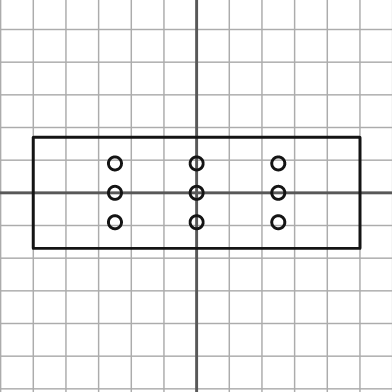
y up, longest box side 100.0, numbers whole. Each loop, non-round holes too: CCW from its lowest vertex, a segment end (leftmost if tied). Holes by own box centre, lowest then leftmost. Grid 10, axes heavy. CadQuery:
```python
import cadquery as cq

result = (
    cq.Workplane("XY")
    .moveTo(-50.0, -17.0)
    .lineTo(50.0, -17.0)
    .lineTo(50.0, 17.0)
    .lineTo(-50.0, 17.0)
    .close()
    .moveTo(-25.0, -9.0)
    .circle(2.0)
    .moveTo(0.0, -9.0)
    .circle(2.0)
    .moveTo(25.0, -9.0)
    .circle(2.0)
    .moveTo(-25.0, 0.0)
    .circle(2.0)
    .moveTo(0.0, 0.0)
    .circle(2.0)
    .moveTo(25.0, 0.0)
    .circle(2.0)
    .moveTo(-25.0, 9.0)
    .circle(2.0)
    .moveTo(0.0, 9.0)
    .circle(2.0)
    .moveTo(25.0, 9.0)
    .circle(2.0)
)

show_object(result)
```